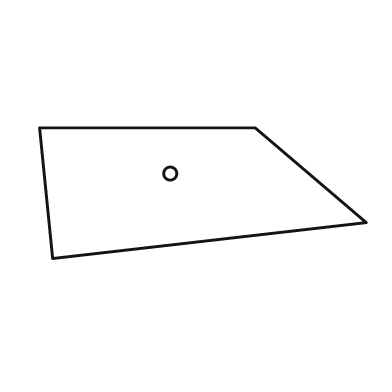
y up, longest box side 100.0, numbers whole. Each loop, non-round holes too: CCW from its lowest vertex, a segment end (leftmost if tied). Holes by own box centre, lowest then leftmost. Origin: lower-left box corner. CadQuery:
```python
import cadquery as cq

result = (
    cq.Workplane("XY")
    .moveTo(4.0, 0.0)
    .lineTo(100.0, 11.0)
    .lineTo(66.0, 40.0)
    .lineTo(0.0, 40.0)
    .close()
    .moveTo(40.0, 26.0)
    .circle(2.0)
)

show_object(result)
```